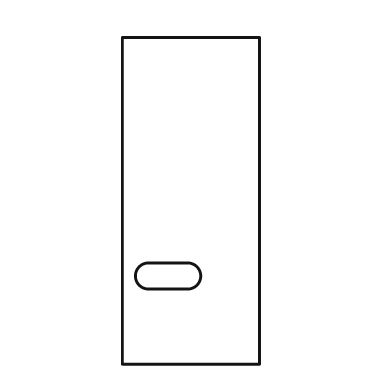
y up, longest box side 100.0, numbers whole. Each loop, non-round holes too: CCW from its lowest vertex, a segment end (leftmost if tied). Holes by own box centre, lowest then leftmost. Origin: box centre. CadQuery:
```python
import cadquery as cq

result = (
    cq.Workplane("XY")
    .moveTo(-21.0, -50.0)
    .lineTo(21.0, -50.0)
    .lineTo(21.0, 50.0)
    .lineTo(-21.0, 50.0)
    .close()
    .moveTo(-13.0, -27.0)
    .lineTo(-1.0, -27.0)
    .threePointArc((3.0, -23.0), (-1.0, -19.0))
    .lineTo(-13.0, -19.0)
    .threePointArc((-17.0, -23.0), (-13.0, -27.0))
    .close()
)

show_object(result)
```